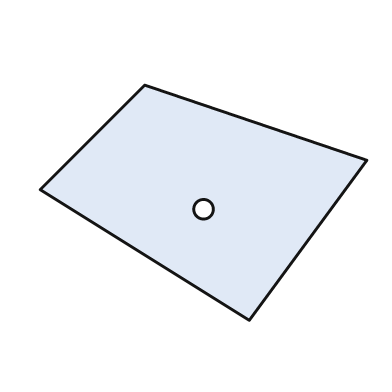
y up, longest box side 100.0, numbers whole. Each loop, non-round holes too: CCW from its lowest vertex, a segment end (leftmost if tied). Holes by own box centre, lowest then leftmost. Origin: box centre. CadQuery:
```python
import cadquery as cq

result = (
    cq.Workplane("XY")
    .moveTo(14.0, -36.0)
    .lineTo(50.0, 13.0)
    .lineTo(-18.0, 36.0)
    .lineTo(-50.0, 4.0)
    .close()
    .moveTo(0.0, -2.0)
    .circle(3.0)
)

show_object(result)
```